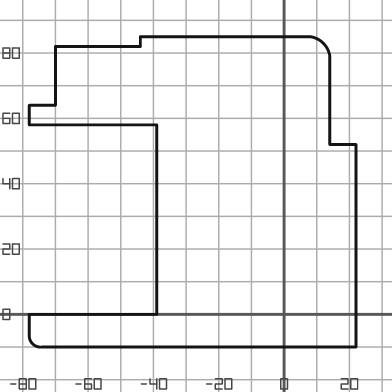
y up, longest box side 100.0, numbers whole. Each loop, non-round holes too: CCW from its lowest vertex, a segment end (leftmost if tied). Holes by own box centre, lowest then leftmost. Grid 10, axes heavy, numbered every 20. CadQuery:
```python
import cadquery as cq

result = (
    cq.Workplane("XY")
    .moveTo(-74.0, -10.0)
    .lineTo(22.0, -10.0)
    .lineTo(22.0, 52.0)
    .lineTo(14.0, 52.0)
    .lineTo(14.0, 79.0)
    .threePointArc((12.0, 83.0), (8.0, 85.0))
    .lineTo(-44.0, 85.0)
    .lineTo(-44.0, 82.0)
    .lineTo(-70.0, 82.0)
    .lineTo(-70.0, 64.0)
    .lineTo(-78.0, 64.0)
    .lineTo(-78.0, 58.0)
    .lineTo(-39.0, 58.0)
    .lineTo(-39.0, 0.0)
    .lineTo(-78.0, 0.0)
    .lineTo(-78.0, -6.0)
    .threePointArc((-77.0, -9.0), (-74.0, -10.0))
    .close()
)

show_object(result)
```